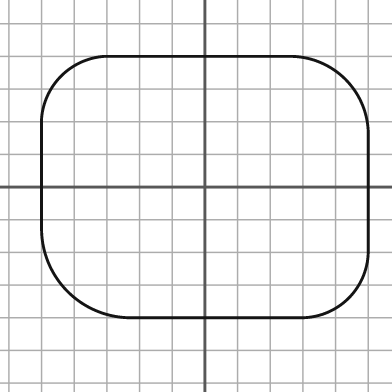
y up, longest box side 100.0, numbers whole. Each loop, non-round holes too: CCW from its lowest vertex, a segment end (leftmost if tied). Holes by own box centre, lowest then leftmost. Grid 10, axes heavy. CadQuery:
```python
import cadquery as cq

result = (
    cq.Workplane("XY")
    .moveTo(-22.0, -40.0)
    .lineTo(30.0, -40.0)
    .threePointArc((44.0, -34.0), (50.0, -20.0))
    .lineTo(50.0, 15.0)
    .threePointArc((43.0, 33.0), (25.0, 40.0))
    .lineTo(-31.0, 40.0)
    .threePointArc((-44.0, 34.0), (-50.0, 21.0))
    .lineTo(-50.0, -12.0)
    .threePointArc((-42.0, -32.0), (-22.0, -40.0))
    .close()
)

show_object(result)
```